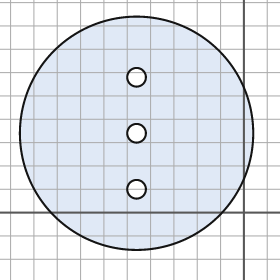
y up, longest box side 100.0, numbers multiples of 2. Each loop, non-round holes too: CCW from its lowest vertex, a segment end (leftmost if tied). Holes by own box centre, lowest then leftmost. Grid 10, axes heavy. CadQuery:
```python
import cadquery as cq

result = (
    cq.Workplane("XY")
    .moveTo(-46.0, 34.0)
    .circle(50.0)
    .moveTo(-46.0, 10.0)
    .circle(4.0)
    .moveTo(-46.0, 34.0)
    .circle(4.0)
    .moveTo(-46.0, 58.0)
    .circle(4.0)
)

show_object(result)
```